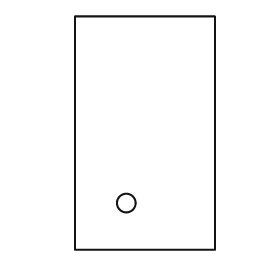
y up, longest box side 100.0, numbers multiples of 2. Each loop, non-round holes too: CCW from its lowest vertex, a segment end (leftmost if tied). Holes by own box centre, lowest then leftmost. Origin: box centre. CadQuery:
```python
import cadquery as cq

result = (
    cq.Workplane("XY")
    .moveTo(-30.0, -50.0)
    .lineTo(30.0, -50.0)
    .lineTo(30.0, 50.0)
    .lineTo(-30.0, 50.0)
    .close()
    .moveTo(-8.0, -30.0)
    .circle(4.0)
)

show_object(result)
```